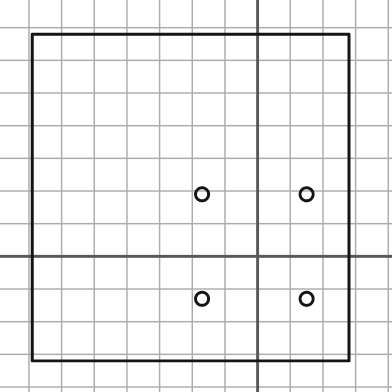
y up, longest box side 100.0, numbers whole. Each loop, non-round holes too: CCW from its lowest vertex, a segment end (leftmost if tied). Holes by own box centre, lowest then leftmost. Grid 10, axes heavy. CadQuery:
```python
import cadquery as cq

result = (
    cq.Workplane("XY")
    .moveTo(-69.0, -32.0)
    .lineTo(28.0, -32.0)
    .lineTo(28.0, 68.0)
    .lineTo(-69.0, 68.0)
    .close()
    .moveTo(-17.0, -13.0)
    .circle(2.0)
    .moveTo(15.0, -13.0)
    .circle(2.0)
    .moveTo(-17.0, 19.0)
    .circle(2.0)
    .moveTo(15.0, 19.0)
    .circle(2.0)
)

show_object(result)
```